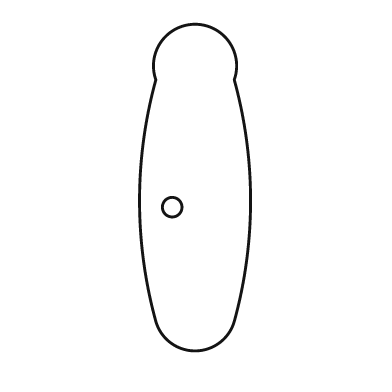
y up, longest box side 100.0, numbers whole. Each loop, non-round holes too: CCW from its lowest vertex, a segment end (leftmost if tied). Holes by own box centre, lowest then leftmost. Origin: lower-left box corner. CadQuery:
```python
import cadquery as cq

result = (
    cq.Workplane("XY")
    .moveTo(5.0, 9.0)
    .threePointArc((17.0, 0.0), (29.0, 9.0))
    .threePointArc((34.0, 46.0), (29.0, 83.0))
    .threePointArc((17.0, 100.0), (5.0, 83.0))
    .threePointArc((0.0, 46.0), (5.0, 9.0))
    .close()
    .moveTo(10.0, 44.0)
    .circle(3.0)
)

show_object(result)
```